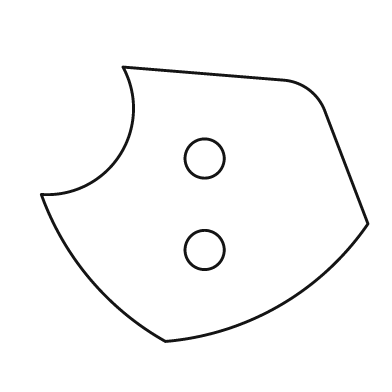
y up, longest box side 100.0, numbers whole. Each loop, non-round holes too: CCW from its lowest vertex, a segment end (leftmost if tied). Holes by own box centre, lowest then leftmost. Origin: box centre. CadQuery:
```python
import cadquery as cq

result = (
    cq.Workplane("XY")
    .moveTo(-12.0, -42.0)
    .threePointArc((23.0, -31.0), (50.0, -6.0))
    .lineTo(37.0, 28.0)
    .threePointArc((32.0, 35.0), (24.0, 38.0))
    .lineTo(-25.0, 42.0)
    .threePointArc((-26.0, 15.0), (-50.0, 3.0))
    .threePointArc((-35.0, -23.0), (-12.0, -42.0))
    .close()
    .moveTo(0.0, -14.0)
    .circle(6.0)
    .moveTo(0.0, 14.0)
    .circle(6.0)
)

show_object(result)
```